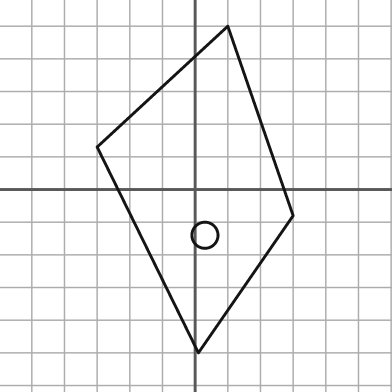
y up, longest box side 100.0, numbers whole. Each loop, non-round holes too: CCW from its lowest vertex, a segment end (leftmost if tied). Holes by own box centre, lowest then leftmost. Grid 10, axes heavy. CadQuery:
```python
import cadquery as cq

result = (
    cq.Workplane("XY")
    .moveTo(1.0, -50.0)
    .lineTo(30.0, -8.0)
    .lineTo(10.0, 50.0)
    .lineTo(-30.0, 13.0)
    .close()
    .moveTo(3.0, -14.0)
    .circle(4.0)
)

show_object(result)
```